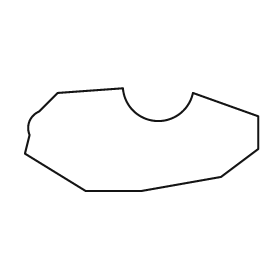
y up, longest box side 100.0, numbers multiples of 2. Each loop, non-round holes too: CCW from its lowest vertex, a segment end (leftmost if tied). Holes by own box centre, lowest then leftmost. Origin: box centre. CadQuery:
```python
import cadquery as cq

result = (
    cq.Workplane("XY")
    .moveTo(-24.0, -22.0)
    .lineTo(0.0, -22.0)
    .lineTo(34.0, -16.0)
    .lineTo(50.0, -4.0)
    .lineTo(50.0, 10.0)
    .lineTo(22.0, 20.0)
    .threePointArc((6.0, 8.0), (-8.0, 22.0))
    .lineTo(-36.0, 20.0)
    .lineTo(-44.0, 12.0)
    .threePointArc((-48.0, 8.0), (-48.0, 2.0))
    .lineTo(-50.0, -6.0)
    .close()
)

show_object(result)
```